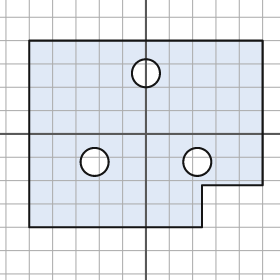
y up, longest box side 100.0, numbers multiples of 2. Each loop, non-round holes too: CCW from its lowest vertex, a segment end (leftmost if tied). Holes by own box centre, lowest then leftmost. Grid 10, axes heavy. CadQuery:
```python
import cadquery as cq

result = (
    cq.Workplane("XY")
    .moveTo(-50.0, -40.0)
    .lineTo(24.0, -40.0)
    .lineTo(24.0, -22.0)
    .lineTo(50.0, -22.0)
    .lineTo(50.0, 40.0)
    .lineTo(-50.0, 40.0)
    .close()
    .moveTo(-22.0, -12.0)
    .circle(6.0)
    .moveTo(22.0, -12.0)
    .circle(6.0)
    .moveTo(0.0, 26.0)
    .circle(6.0)
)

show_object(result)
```